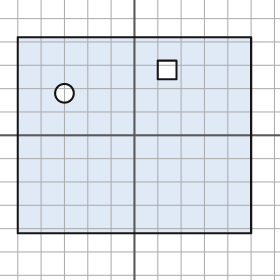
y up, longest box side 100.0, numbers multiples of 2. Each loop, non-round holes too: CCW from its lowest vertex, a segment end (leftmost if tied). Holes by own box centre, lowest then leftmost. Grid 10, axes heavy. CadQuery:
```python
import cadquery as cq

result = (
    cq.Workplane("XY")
    .moveTo(-50.0, -42.0)
    .lineTo(50.0, -42.0)
    .lineTo(50.0, 42.0)
    .lineTo(-50.0, 42.0)
    .close()
    .moveTo(-30.0, 18.0)
    .circle(4.0)
    .moveTo(10.0, 24.0)
    .lineTo(18.0, 24.0)
    .lineTo(18.0, 32.0)
    .lineTo(10.0, 32.0)
    .close()
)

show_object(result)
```